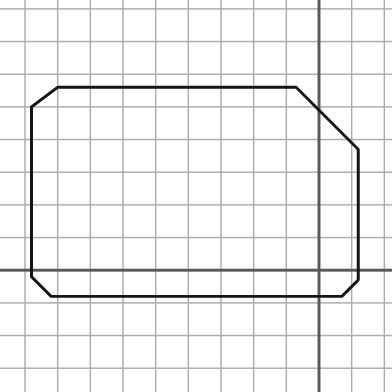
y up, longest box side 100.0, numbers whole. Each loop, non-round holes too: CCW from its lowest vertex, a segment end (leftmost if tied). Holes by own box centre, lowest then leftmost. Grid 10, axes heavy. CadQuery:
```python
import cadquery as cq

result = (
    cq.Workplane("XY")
    .moveTo(-82.0, -8.0)
    .lineTo(7.0, -8.0)
    .lineTo(12.0, -3.0)
    .lineTo(12.0, 37.0)
    .lineTo(-7.0, 56.0)
    .lineTo(-80.0, 56.0)
    .lineTo(-88.0, 50.0)
    .lineTo(-88.0, -2.0)
    .close()
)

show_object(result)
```